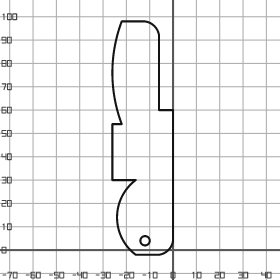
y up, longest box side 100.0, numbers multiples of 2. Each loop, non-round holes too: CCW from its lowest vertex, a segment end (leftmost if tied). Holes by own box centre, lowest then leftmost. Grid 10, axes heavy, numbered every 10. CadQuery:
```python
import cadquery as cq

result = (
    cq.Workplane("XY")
    .moveTo(-16.0, -2.0)
    .lineTo(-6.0, -2.0)
    .threePointArc((-2.0, 0.0), (0.0, 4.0))
    .lineTo(0.0, 60.0)
    .lineTo(-6.0, 60.0)
    .lineTo(-6.0, 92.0)
    .threePointArc((-8.0, 96.0), (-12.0, 98.0))
    .lineTo(-22.0, 98.0)
    .threePointArc((-26.0, 76.0), (-22.0, 54.0))
    .lineTo(-26.0, 54.0)
    .lineTo(-26.0, 30.0)
    .lineTo(-16.0, 30.0)
    .threePointArc((-24.0, 14.0), (-16.0, -2.0))
    .close()
    .moveTo(-12.0, 4.0)
    .circle(2.0)
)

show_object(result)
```